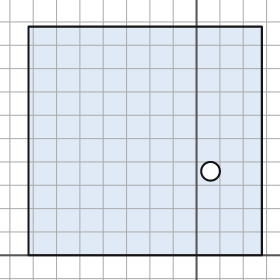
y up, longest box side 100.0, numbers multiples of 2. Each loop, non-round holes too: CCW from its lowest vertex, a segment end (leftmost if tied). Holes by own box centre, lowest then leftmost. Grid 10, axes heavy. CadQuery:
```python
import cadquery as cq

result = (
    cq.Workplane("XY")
    .moveTo(-72.0, 0.0)
    .lineTo(28.0, 0.0)
    .lineTo(28.0, 98.0)
    .lineTo(-72.0, 98.0)
    .close()
    .moveTo(6.0, 36.0)
    .circle(4.0)
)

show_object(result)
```